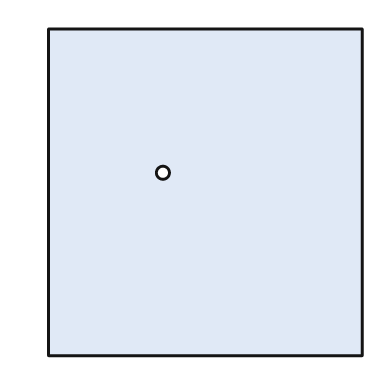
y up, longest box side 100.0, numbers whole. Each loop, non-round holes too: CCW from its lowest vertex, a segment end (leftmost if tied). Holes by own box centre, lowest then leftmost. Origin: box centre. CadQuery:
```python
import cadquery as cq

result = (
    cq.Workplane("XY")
    .moveTo(-48.0, -50.0)
    .lineTo(48.0, -50.0)
    .lineTo(48.0, 50.0)
    .lineTo(-48.0, 50.0)
    .close()
    .moveTo(-13.0, 6.0)
    .circle(2.0)
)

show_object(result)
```